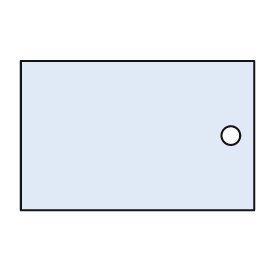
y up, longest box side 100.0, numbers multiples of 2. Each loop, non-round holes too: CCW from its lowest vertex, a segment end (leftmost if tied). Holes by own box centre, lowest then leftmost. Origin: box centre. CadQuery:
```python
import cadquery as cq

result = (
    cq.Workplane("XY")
    .moveTo(-50.0, -32.0)
    .lineTo(50.0, -32.0)
    .lineTo(50.0, 32.0)
    .lineTo(-50.0, 32.0)
    .close()
    .moveTo(40.0, 0.0)
    .circle(4.0)
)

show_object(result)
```